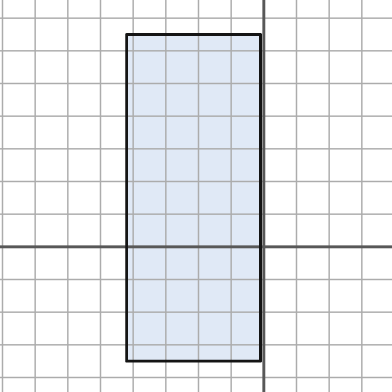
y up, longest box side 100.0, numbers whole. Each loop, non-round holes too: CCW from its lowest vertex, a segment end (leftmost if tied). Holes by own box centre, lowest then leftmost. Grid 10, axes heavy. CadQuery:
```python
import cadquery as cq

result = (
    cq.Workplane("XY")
    .moveTo(-42.0, -35.0)
    .lineTo(-1.0, -35.0)
    .lineTo(-1.0, 65.0)
    .lineTo(-42.0, 65.0)
    .close()
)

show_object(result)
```